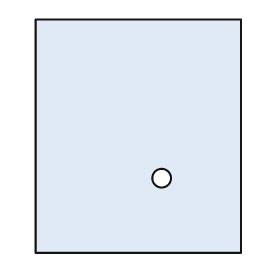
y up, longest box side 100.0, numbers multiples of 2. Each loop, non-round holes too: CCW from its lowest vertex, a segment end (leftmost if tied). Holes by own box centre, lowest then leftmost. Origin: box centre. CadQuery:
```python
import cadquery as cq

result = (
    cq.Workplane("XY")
    .moveTo(-44.0, -50.0)
    .lineTo(44.0, -50.0)
    .lineTo(44.0, 50.0)
    .lineTo(-44.0, 50.0)
    .close()
    .moveTo(10.0, -18.0)
    .circle(4.0)
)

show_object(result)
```